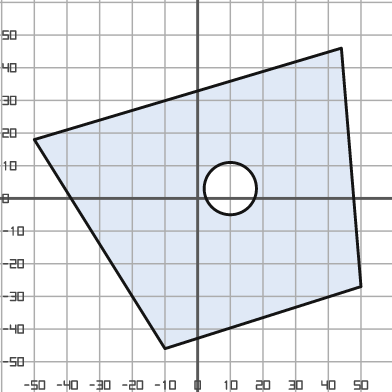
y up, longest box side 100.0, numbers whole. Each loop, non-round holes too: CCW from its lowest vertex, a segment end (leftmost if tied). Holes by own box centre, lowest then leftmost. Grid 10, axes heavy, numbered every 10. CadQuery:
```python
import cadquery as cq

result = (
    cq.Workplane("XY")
    .moveTo(-10.0, -46.0)
    .lineTo(50.0, -27.0)
    .lineTo(44.0, 46.0)
    .lineTo(-50.0, 18.0)
    .close()
    .moveTo(10.0, 3.0)
    .circle(8.0)
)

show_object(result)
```